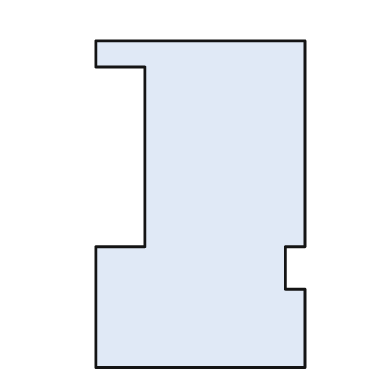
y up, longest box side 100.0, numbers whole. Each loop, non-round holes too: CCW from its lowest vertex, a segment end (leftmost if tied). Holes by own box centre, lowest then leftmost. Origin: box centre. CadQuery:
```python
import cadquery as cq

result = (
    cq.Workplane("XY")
    .moveTo(-32.0, -50.0)
    .lineTo(32.0, -50.0)
    .lineTo(32.0, -26.0)
    .lineTo(26.0, -26.0)
    .lineTo(26.0, -13.0)
    .lineTo(32.0, -13.0)
    .lineTo(32.0, 50.0)
    .lineTo(-32.0, 50.0)
    .lineTo(-32.0, 42.0)
    .lineTo(-17.0, 42.0)
    .lineTo(-17.0, -13.0)
    .lineTo(-32.0, -13.0)
    .close()
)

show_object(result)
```